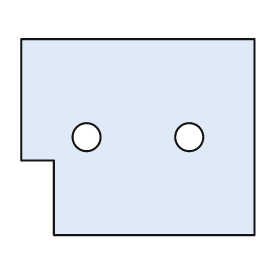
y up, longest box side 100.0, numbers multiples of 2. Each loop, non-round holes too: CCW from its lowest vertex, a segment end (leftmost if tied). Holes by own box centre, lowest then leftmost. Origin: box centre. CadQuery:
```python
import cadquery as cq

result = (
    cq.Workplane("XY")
    .moveTo(-36.0, -42.0)
    .lineTo(50.0, -42.0)
    .lineTo(50.0, 42.0)
    .lineTo(-50.0, 42.0)
    .lineTo(-50.0, -10.0)
    .lineTo(-36.0, -10.0)
    .close()
    .moveTo(-22.0, 0.0)
    .circle(6.0)
    .moveTo(22.0, 0.0)
    .circle(6.0)
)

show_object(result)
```